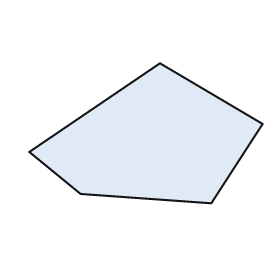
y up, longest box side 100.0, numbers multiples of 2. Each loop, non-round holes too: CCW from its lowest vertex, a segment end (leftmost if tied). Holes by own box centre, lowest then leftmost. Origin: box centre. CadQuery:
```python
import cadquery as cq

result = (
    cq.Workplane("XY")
    .moveTo(28.0, -30.0)
    .lineTo(50.0, 4.0)
    .lineTo(6.0, 30.0)
    .lineTo(-50.0, -8.0)
    .lineTo(-28.0, -26.0)
    .close()
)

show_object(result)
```